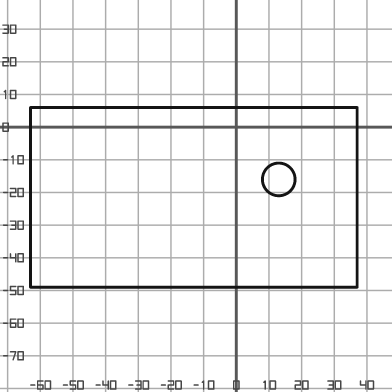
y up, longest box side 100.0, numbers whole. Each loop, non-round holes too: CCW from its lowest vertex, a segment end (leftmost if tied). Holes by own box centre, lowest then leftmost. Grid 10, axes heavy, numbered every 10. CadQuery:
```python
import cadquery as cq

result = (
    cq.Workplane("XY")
    .moveTo(-63.0, -49.0)
    .lineTo(37.0, -49.0)
    .lineTo(37.0, 6.0)
    .lineTo(-63.0, 6.0)
    .close()
    .moveTo(13.0, -16.0)
    .circle(5.0)
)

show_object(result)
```